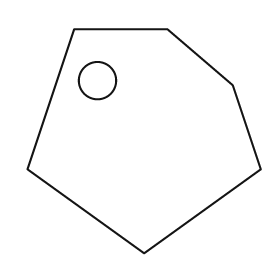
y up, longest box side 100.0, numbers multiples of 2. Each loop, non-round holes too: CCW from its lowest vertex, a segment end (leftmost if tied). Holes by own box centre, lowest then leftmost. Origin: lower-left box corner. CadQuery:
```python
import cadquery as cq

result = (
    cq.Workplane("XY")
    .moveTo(50.0, 0.0)
    .lineTo(100.0, 36.0)
    .lineTo(88.0, 72.0)
    .lineTo(60.0, 96.0)
    .lineTo(20.0, 96.0)
    .lineTo(0.0, 36.0)
    .close()
    .moveTo(30.0, 74.0)
    .circle(8.0)
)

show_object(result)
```